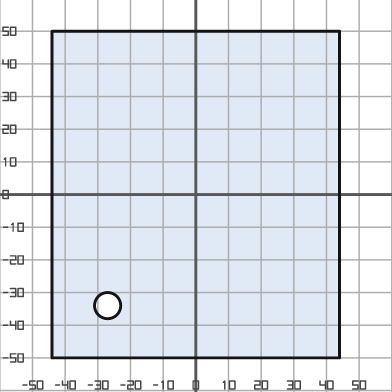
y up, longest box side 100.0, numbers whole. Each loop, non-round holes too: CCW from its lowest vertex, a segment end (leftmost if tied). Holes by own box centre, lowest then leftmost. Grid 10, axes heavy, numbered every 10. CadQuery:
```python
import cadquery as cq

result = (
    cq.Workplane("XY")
    .moveTo(-44.0, -50.0)
    .lineTo(44.0, -50.0)
    .lineTo(44.0, 50.0)
    .lineTo(-44.0, 50.0)
    .close()
    .moveTo(-27.0, -34.0)
    .circle(4.0)
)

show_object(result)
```